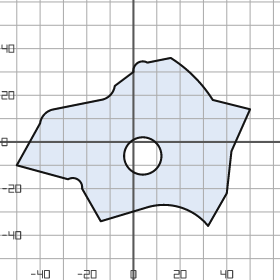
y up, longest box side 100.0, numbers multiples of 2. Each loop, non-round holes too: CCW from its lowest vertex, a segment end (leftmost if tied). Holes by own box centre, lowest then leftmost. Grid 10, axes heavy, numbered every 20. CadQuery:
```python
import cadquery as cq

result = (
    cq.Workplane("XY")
    .moveTo(32.0, -36.0)
    .lineTo(40.0, -22.0)
    .lineTo(42.0, -4.0)
    .lineTo(50.0, 14.0)
    .lineTo(34.0, 18.0)
    .threePointArc((26.0, 28.0), (16.0, 36.0))
    .lineTo(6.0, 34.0)
    .threePointArc((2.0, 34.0), (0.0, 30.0))
    .lineTo(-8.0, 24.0)
    .threePointArc((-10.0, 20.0), (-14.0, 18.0))
    .lineTo(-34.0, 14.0)
    .threePointArc((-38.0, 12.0), (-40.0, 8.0))
    .lineTo(-50.0, -10.0)
    .lineTo(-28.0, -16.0)
    .threePointArc((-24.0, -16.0), (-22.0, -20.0))
    .lineTo(-14.0, -34.0)
    .lineTo(6.0, -28.0)
    .threePointArc((20.0, -28.0), (32.0, -36.0))
    .close()
    .moveTo(4.0, -6.0)
    .circle(8.0)
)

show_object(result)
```